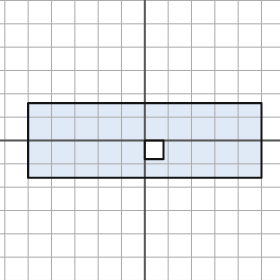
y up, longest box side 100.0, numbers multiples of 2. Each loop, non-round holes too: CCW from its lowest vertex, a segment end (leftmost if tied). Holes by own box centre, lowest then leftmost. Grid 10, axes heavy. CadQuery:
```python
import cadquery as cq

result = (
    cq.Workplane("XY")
    .moveTo(-50.0, -16.0)
    .lineTo(50.0, -16.0)
    .lineTo(50.0, 16.0)
    .lineTo(-50.0, 16.0)
    .close()
    .moveTo(0.0, -8.0)
    .lineTo(8.0, -8.0)
    .lineTo(8.0, 0.0)
    .lineTo(0.0, 0.0)
    .close()
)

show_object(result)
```